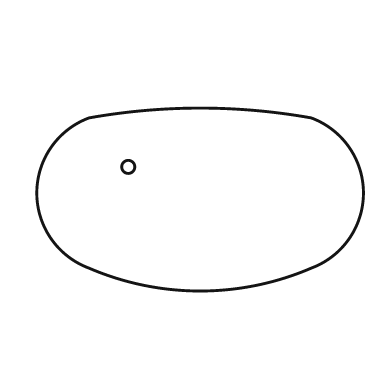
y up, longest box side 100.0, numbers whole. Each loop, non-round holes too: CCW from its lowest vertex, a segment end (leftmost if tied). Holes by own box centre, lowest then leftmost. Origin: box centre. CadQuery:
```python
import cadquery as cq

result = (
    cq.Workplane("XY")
    .moveTo(-34.0, -21.0)
    .threePointArc((0.0, -28.0), (34.0, -21.0))
    .threePointArc((50.0, 2.0), (34.0, 25.0))
    .threePointArc((0.0, 28.0), (-34.0, 25.0))
    .threePointArc((-50.0, 2.0), (-34.0, -21.0))
    .close()
    .moveTo(-22.0, 10.0)
    .circle(2.0)
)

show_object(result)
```